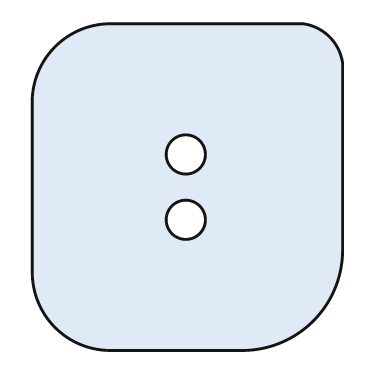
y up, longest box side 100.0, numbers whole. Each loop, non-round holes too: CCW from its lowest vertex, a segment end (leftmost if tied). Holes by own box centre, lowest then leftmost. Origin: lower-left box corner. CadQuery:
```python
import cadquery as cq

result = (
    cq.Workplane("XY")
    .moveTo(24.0, 0.0)
    .lineTo(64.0, 0.0)
    .threePointArc((86.0, 9.0), (95.0, 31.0))
    .lineTo(95.0, 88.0)
    .threePointArc((91.0, 96.0), (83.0, 100.0))
    .lineTo(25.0, 100.0)
    .threePointArc((7.0, 93.0), (0.0, 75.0))
    .lineTo(0.0, 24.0)
    .threePointArc((7.0, 7.0), (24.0, 0.0))
    .close()
    .moveTo(47.0, 40.0)
    .circle(6.0)
    .moveTo(47.0, 60.0)
    .circle(6.0)
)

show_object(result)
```